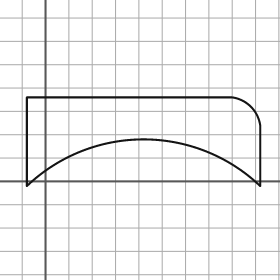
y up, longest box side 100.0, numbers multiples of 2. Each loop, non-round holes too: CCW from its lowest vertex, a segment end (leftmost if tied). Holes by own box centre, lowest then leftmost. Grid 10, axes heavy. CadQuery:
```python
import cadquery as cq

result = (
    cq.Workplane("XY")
    .moveTo(-8.0, -2.0)
    .threePointArc((42.0, 18.0), (92.0, -2.0))
    .lineTo(92.0, 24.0)
    .threePointArc((88.0, 32.0), (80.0, 36.0))
    .lineTo(-8.0, 36.0)
    .close()
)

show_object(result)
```